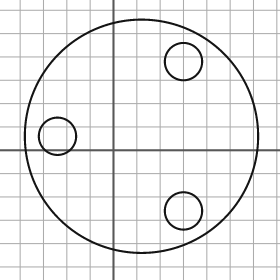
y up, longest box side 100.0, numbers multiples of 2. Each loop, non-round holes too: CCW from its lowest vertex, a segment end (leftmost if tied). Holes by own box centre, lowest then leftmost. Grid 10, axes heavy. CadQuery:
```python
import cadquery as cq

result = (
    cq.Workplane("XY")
    .moveTo(12.0, 6.0)
    .circle(50.0)
    .moveTo(30.0, -26.0)
    .circle(8.0)
    .moveTo(-24.0, 6.0)
    .circle(8.0)
    .moveTo(30.0, 38.0)
    .circle(8.0)
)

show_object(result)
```